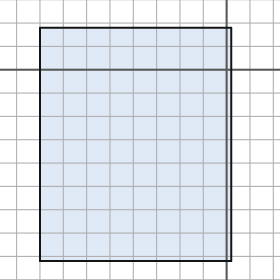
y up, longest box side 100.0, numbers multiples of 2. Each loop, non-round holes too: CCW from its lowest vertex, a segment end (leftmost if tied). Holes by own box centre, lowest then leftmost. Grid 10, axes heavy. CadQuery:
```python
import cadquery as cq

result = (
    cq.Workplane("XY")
    .moveTo(-80.0, -82.0)
    .lineTo(2.0, -82.0)
    .lineTo(2.0, 18.0)
    .lineTo(-80.0, 18.0)
    .close()
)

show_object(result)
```